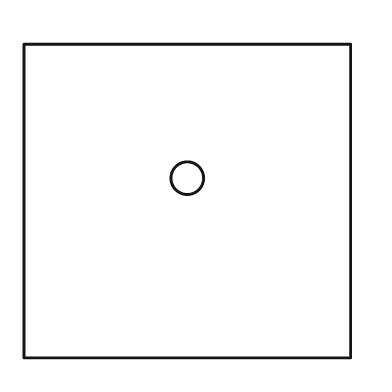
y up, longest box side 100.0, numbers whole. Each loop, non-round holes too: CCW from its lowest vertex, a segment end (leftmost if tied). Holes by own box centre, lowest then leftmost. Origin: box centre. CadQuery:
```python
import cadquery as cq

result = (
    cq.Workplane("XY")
    .moveTo(-50.0, -48.0)
    .lineTo(50.0, -48.0)
    .lineTo(50.0, 48.0)
    .lineTo(-50.0, 48.0)
    .close()
    .moveTo(0.0, 7.0)
    .circle(5.0)
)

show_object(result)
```